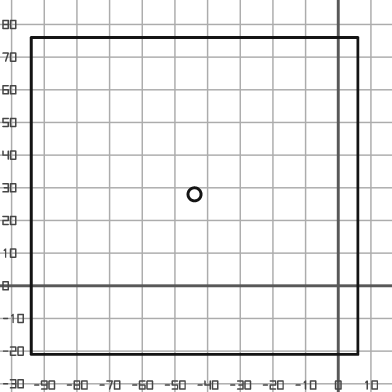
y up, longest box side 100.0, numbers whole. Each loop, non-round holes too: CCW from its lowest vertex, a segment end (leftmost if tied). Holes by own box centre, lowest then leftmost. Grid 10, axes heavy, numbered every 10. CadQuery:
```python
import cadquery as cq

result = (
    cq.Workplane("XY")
    .moveTo(-94.0, -21.0)
    .lineTo(6.0, -21.0)
    .lineTo(6.0, 76.0)
    .lineTo(-94.0, 76.0)
    .close()
    .moveTo(-44.0, 28.0)
    .circle(2.0)
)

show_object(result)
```